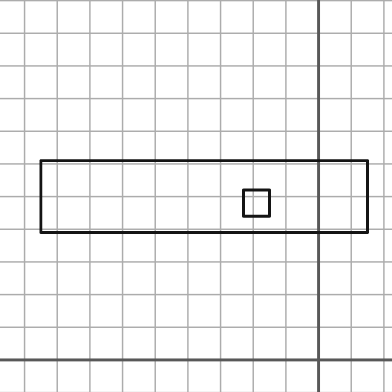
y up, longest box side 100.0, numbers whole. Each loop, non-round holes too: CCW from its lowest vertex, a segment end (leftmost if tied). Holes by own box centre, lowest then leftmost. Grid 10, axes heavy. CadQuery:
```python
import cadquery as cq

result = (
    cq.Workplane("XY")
    .moveTo(-85.0, 39.0)
    .lineTo(15.0, 39.0)
    .lineTo(15.0, 61.0)
    .lineTo(-85.0, 61.0)
    .close()
    .moveTo(-23.0, 44.0)
    .lineTo(-15.0, 44.0)
    .lineTo(-15.0, 52.0)
    .lineTo(-23.0, 52.0)
    .close()
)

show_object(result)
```